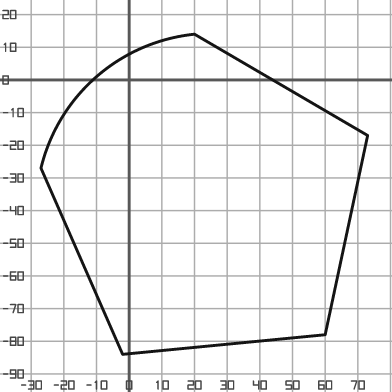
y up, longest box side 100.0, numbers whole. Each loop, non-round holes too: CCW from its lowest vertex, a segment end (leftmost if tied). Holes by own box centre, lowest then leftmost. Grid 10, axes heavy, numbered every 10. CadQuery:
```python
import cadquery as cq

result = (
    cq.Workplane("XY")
    .moveTo(-2.0, -84.0)
    .lineTo(60.0, -78.0)
    .lineTo(73.0, -17.0)
    .lineTo(20.0, 14.0)
    .threePointArc((-10.0, 1.0), (-27.0, -27.0))
    .close()
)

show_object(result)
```